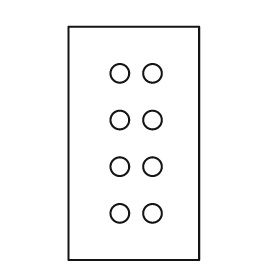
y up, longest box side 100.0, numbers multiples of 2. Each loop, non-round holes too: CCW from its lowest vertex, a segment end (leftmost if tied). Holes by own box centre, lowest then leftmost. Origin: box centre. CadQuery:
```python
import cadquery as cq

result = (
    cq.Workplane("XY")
    .moveTo(-28.0, -50.0)
    .lineTo(28.0, -50.0)
    .lineTo(28.0, 50.0)
    .lineTo(-28.0, 50.0)
    .close()
    .moveTo(-6.0, -30.0)
    .circle(4.0)
    .moveTo(8.0, -30.0)
    .circle(4.0)
    .moveTo(-6.0, -10.0)
    .circle(4.0)
    .moveTo(8.0, -10.0)
    .circle(4.0)
    .moveTo(-6.0, 10.0)
    .circle(4.0)
    .moveTo(8.0, 10.0)
    .circle(4.0)
    .moveTo(-6.0, 30.0)
    .circle(4.0)
    .moveTo(8.0, 30.0)
    .circle(4.0)
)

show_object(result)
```